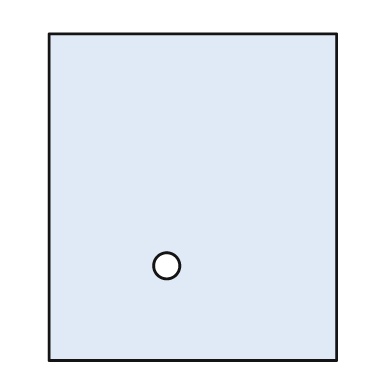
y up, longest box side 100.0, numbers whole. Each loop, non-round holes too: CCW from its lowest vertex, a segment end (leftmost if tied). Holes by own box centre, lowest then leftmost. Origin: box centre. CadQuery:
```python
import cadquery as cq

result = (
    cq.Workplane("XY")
    .moveTo(-44.0, -50.0)
    .lineTo(44.0, -50.0)
    .lineTo(44.0, 50.0)
    .lineTo(-44.0, 50.0)
    .close()
    .moveTo(-8.0, -21.0)
    .circle(4.0)
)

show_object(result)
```